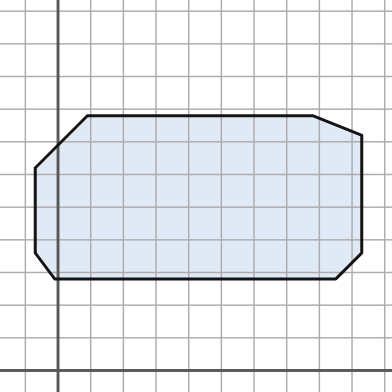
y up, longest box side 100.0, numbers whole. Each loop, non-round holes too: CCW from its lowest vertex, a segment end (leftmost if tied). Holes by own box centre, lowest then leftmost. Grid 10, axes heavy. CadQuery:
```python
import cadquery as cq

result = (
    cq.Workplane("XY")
    .moveTo(-1.0, 28.0)
    .lineTo(85.0, 28.0)
    .lineTo(93.0, 36.0)
    .lineTo(93.0, 72.0)
    .lineTo(78.0, 78.0)
    .lineTo(9.0, 78.0)
    .lineTo(-7.0, 62.0)
    .lineTo(-7.0, 36.0)
    .close()
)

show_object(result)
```